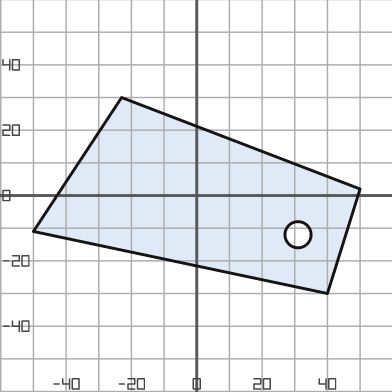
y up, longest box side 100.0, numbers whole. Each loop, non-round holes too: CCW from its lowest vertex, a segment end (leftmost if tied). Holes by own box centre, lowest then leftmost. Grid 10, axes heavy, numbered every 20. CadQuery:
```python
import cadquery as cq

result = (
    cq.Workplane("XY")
    .moveTo(40.0, -30.0)
    .lineTo(50.0, 2.0)
    .lineTo(-23.0, 30.0)
    .lineTo(-50.0, -11.0)
    .close()
    .moveTo(31.0, -12.0)
    .circle(4.0)
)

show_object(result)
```